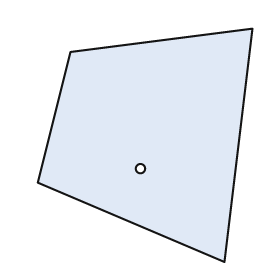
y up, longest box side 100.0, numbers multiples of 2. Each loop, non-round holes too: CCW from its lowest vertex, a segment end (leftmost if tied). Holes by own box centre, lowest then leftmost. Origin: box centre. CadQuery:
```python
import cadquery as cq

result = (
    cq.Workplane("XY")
    .moveTo(34.0, -50.0)
    .lineTo(46.0, 50.0)
    .lineTo(-32.0, 40.0)
    .lineTo(-46.0, -16.0)
    .close()
    .moveTo(-2.0, -10.0)
    .circle(2.0)
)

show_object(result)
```